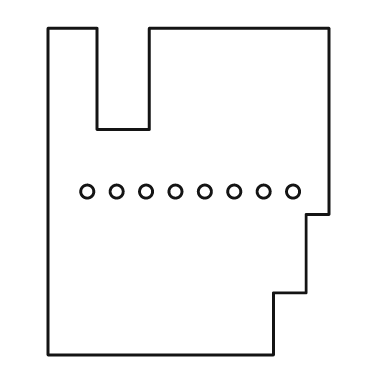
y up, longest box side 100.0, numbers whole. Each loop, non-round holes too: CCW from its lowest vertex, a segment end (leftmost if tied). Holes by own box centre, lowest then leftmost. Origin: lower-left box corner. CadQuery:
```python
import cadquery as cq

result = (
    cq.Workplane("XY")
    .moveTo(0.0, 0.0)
    .lineTo(69.0, 0.0)
    .lineTo(69.0, 19.0)
    .lineTo(79.0, 19.0)
    .lineTo(79.0, 43.0)
    .lineTo(86.0, 43.0)
    .lineTo(86.0, 100.0)
    .lineTo(31.0, 100.0)
    .lineTo(31.0, 69.0)
    .lineTo(15.0, 69.0)
    .lineTo(15.0, 100.0)
    .lineTo(0.0, 100.0)
    .close()
    .moveTo(12.0, 50.0)
    .circle(2.0)
    .moveTo(21.0, 50.0)
    .circle(2.0)
    .moveTo(30.0, 50.0)
    .circle(2.0)
    .moveTo(39.0, 50.0)
    .circle(2.0)
    .moveTo(48.0, 50.0)
    .circle(2.0)
    .moveTo(57.0, 50.0)
    .circle(2.0)
    .moveTo(66.0, 50.0)
    .circle(2.0)
    .moveTo(75.0, 50.0)
    .circle(2.0)
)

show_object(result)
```